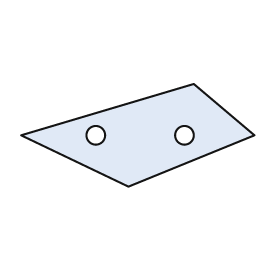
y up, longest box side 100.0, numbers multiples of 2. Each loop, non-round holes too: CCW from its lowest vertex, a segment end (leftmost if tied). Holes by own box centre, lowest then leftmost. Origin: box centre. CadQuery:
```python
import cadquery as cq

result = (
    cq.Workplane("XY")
    .moveTo(-4.0, -22.0)
    .lineTo(50.0, 0.0)
    .lineTo(24.0, 22.0)
    .lineTo(-50.0, 0.0)
    .close()
    .moveTo(-18.0, 0.0)
    .circle(4.0)
    .moveTo(20.0, 0.0)
    .circle(4.0)
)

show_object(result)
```